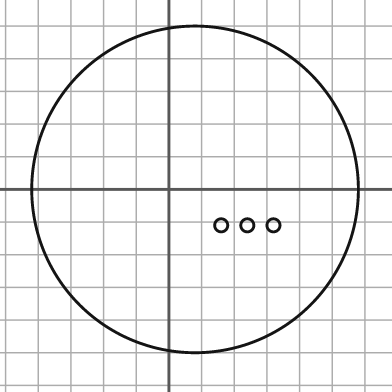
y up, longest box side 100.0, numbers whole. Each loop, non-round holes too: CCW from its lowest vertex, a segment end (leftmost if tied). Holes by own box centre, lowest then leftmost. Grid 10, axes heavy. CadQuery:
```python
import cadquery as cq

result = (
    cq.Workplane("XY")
    .moveTo(8.0, 0.0)
    .circle(50.0)
    .moveTo(16.0, -11.0)
    .circle(2.0)
    .moveTo(24.0, -11.0)
    .circle(2.0)
    .moveTo(32.0, -11.0)
    .circle(2.0)
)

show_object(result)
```